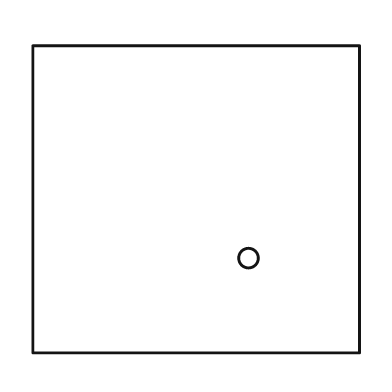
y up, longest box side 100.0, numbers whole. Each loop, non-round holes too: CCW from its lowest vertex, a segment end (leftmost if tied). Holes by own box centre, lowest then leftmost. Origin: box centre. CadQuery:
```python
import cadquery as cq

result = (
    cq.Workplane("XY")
    .moveTo(-50.0, -47.0)
    .lineTo(50.0, -47.0)
    .lineTo(50.0, 47.0)
    .lineTo(-50.0, 47.0)
    .close()
    .moveTo(16.0, -18.0)
    .circle(3.0)
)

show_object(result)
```